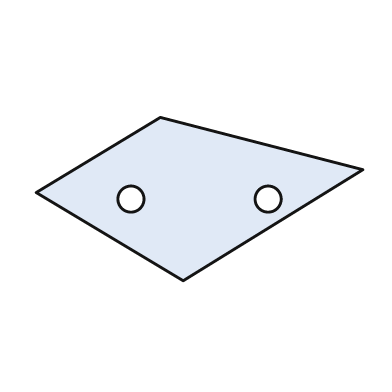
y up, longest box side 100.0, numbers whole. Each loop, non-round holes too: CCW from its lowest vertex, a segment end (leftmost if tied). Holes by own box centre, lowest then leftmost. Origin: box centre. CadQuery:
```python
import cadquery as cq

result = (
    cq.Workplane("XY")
    .moveTo(-5.0, -25.0)
    .lineTo(50.0, 9.0)
    .lineTo(-12.0, 25.0)
    .lineTo(-50.0, 2.0)
    .close()
    .moveTo(-21.0, 0.0)
    .circle(4.0)
    .moveTo(21.0, 0.0)
    .circle(4.0)
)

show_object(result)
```